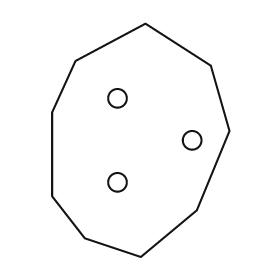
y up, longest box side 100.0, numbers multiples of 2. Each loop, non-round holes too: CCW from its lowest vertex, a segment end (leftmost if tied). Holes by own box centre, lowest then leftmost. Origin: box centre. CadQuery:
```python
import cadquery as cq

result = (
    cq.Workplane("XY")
    .moveTo(0.0, -50.0)
    .lineTo(24.0, -30.0)
    .lineTo(38.0, 4.0)
    .lineTo(30.0, 32.0)
    .lineTo(2.0, 50.0)
    .lineTo(-28.0, 34.0)
    .lineTo(-38.0, 12.0)
    .lineTo(-38.0, -24.0)
    .lineTo(-24.0, -42.0)
    .close()
    .moveTo(-10.0, -18.0)
    .circle(4.0)
    .moveTo(22.0, 0.0)
    .circle(4.0)
    .moveTo(-10.0, 18.0)
    .circle(4.0)
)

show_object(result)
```